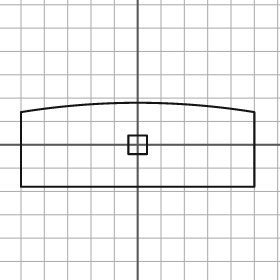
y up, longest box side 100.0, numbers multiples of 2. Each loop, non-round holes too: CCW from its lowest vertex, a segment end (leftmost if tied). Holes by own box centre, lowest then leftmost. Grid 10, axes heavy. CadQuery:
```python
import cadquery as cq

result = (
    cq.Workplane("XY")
    .moveTo(-50.0, -18.0)
    .lineTo(50.0, -18.0)
    .lineTo(50.0, 14.0)
    .threePointArc((0.0, 18.0), (-50.0, 14.0))
    .close()
    .moveTo(-4.0, -4.0)
    .lineTo(4.0, -4.0)
    .lineTo(4.0, 4.0)
    .lineTo(-4.0, 4.0)
    .close()
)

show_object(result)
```